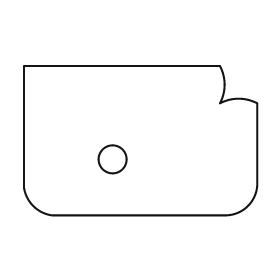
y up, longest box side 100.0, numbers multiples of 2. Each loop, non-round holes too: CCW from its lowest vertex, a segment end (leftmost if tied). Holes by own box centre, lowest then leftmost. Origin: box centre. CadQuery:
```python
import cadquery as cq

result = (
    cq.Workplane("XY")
    .moveTo(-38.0, -32.0)
    .lineTo(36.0, -32.0)
    .threePointArc((46.0, -28.0), (50.0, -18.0))
    .lineTo(50.0, 16.0)
    .threePointArc((42.0, 18.0), (34.0, 16.0))
    .threePointArc((36.0, 24.0), (34.0, 32.0))
    .lineTo(-50.0, 32.0)
    .lineTo(-50.0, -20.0)
    .threePointArc((-46.0, -28.0), (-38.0, -32.0))
    .close()
    .moveTo(-12.0, -8.0)
    .circle(6.0)
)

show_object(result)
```